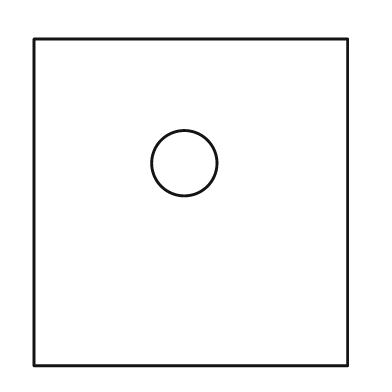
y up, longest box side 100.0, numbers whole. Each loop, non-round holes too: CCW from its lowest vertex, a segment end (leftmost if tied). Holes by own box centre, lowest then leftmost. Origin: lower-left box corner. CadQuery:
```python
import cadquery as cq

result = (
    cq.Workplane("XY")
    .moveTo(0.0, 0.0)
    .lineTo(96.0, 0.0)
    .lineTo(96.0, 100.0)
    .lineTo(0.0, 100.0)
    .close()
    .moveTo(46.0, 62.0)
    .circle(10.0)
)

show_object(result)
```